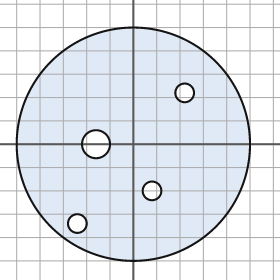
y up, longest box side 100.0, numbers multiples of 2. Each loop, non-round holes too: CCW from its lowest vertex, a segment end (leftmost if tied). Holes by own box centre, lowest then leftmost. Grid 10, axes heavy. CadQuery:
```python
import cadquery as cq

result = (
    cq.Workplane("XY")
    .moveTo(0.0, 0.0)
    .circle(50.0)
    .moveTo(-24.0, -34.0)
    .circle(4.0)
    .moveTo(8.0, -20.0)
    .circle(4.0)
    .moveTo(-16.0, 0.0)
    .circle(6.0)
    .moveTo(22.0, 22.0)
    .circle(4.0)
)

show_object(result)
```